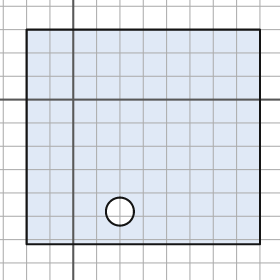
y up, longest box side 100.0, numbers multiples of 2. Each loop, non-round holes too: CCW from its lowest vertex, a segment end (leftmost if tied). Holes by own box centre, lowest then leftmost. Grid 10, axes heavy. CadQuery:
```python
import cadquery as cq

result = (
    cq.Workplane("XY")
    .moveTo(-20.0, -62.0)
    .lineTo(80.0, -62.0)
    .lineTo(80.0, 30.0)
    .lineTo(-20.0, 30.0)
    .close()
    .moveTo(20.0, -48.0)
    .circle(6.0)
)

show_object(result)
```